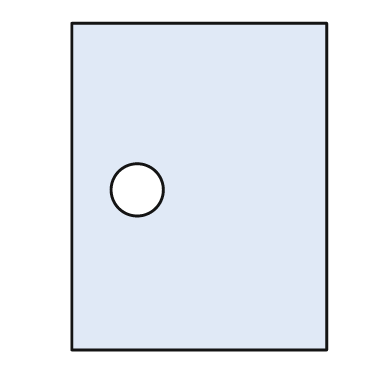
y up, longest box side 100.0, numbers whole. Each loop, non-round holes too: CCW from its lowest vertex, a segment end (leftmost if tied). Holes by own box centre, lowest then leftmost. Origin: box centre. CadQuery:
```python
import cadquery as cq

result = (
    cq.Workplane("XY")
    .moveTo(-39.0, -50.0)
    .lineTo(39.0, -50.0)
    .lineTo(39.0, 50.0)
    .lineTo(-39.0, 50.0)
    .close()
    .moveTo(-19.0, -1.0)
    .circle(8.0)
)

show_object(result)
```